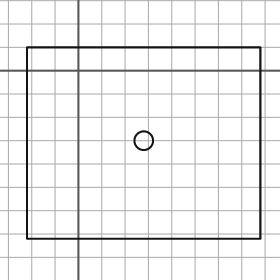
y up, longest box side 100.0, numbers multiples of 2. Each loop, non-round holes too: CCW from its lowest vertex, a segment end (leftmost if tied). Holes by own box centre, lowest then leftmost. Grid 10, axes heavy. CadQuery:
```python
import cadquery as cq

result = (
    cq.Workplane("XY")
    .moveTo(-22.0, -72.0)
    .lineTo(78.0, -72.0)
    .lineTo(78.0, 10.0)
    .lineTo(-22.0, 10.0)
    .close()
    .moveTo(28.0, -30.0)
    .circle(4.0)
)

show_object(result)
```